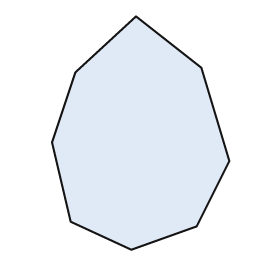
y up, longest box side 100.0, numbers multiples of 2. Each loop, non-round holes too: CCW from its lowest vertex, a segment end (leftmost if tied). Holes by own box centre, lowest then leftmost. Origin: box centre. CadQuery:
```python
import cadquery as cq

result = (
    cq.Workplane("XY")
    .moveTo(-4.0, -50.0)
    .lineTo(24.0, -40.0)
    .lineTo(38.0, -12.0)
    .lineTo(26.0, 28.0)
    .lineTo(-2.0, 50.0)
    .lineTo(-28.0, 26.0)
    .lineTo(-38.0, -4.0)
    .lineTo(-30.0, -38.0)
    .close()
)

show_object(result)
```